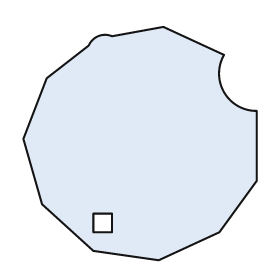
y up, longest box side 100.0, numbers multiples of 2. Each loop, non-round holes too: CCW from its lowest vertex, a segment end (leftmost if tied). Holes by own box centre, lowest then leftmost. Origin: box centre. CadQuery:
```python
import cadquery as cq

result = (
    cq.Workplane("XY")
    .moveTo(8.0, -50.0)
    .lineTo(34.0, -38.0)
    .lineTo(50.0, -16.0)
    .lineTo(50.0, 14.0)
    .threePointArc((36.0, 22.0), (36.0, 38.0))
    .lineTo(10.0, 50.0)
    .lineTo(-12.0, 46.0)
    .threePointArc((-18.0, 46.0), (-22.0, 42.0))
    .lineTo(-40.0, 28.0)
    .lineTo(-50.0, 2.0)
    .lineTo(-42.0, -26.0)
    .lineTo(-20.0, -46.0)
    .close()
    .moveTo(-20.0, -38.0)
    .lineTo(-12.0, -38.0)
    .lineTo(-12.0, -30.0)
    .lineTo(-20.0, -30.0)
    .close()
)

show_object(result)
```